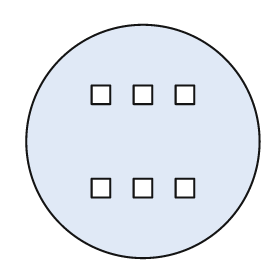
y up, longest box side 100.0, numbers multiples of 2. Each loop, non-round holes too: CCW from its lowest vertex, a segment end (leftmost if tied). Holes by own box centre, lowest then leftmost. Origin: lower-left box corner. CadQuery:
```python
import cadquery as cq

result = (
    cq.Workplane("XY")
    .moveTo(50.0, 50.0)
    .circle(50.0)
    .moveTo(28.0, 26.0)
    .lineTo(36.0, 26.0)
    .lineTo(36.0, 34.0)
    .lineTo(28.0, 34.0)
    .close()
    .moveTo(46.0, 26.0)
    .lineTo(54.0, 26.0)
    .lineTo(54.0, 34.0)
    .lineTo(46.0, 34.0)
    .close()
    .moveTo(64.0, 26.0)
    .lineTo(72.0, 26.0)
    .lineTo(72.0, 34.0)
    .lineTo(64.0, 34.0)
    .close()
    .moveTo(28.0, 66.0)
    .lineTo(36.0, 66.0)
    .lineTo(36.0, 74.0)
    .lineTo(28.0, 74.0)
    .close()
    .moveTo(46.0, 66.0)
    .lineTo(54.0, 66.0)
    .lineTo(54.0, 74.0)
    .lineTo(46.0, 74.0)
    .close()
    .moveTo(64.0, 66.0)
    .lineTo(72.0, 66.0)
    .lineTo(72.0, 74.0)
    .lineTo(64.0, 74.0)
    .close()
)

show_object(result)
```